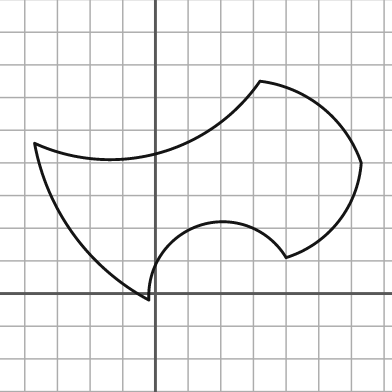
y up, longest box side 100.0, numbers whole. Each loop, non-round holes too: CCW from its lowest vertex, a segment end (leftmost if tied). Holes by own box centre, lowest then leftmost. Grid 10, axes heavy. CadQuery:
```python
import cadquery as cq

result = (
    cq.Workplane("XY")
    .moveTo(-2.0, -2.0)
    .threePointArc((14.0, 21.0), (40.0, 11.0))
    .threePointArc((56.0, 22.0), (63.0, 40.0))
    .threePointArc((51.0, 57.0), (32.0, 65.0))
    .threePointArc((1.0, 43.0), (-37.0, 46.0))
    .threePointArc((-25.0, 18.0), (-2.0, -2.0))
    .close()
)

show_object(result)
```